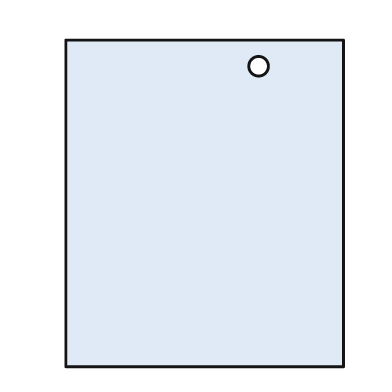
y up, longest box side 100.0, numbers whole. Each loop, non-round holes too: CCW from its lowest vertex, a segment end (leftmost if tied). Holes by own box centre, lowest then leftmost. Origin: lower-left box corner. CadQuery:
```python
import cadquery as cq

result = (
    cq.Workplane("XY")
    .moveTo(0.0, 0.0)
    .lineTo(85.0, 0.0)
    .lineTo(85.0, 100.0)
    .lineTo(0.0, 100.0)
    .close()
    .moveTo(59.0, 92.0)
    .circle(3.0)
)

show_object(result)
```